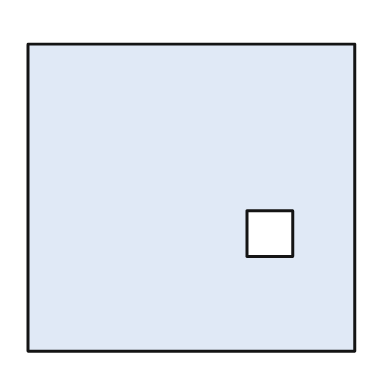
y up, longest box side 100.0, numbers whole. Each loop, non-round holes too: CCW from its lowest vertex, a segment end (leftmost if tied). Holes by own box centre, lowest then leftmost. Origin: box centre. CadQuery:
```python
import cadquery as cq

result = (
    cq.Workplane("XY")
    .moveTo(-50.0, -47.0)
    .lineTo(50.0, -47.0)
    .lineTo(50.0, 47.0)
    .lineTo(-50.0, 47.0)
    .close()
    .moveTo(17.0, -18.0)
    .lineTo(31.0, -18.0)
    .lineTo(31.0, -4.0)
    .lineTo(17.0, -4.0)
    .close()
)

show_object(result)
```